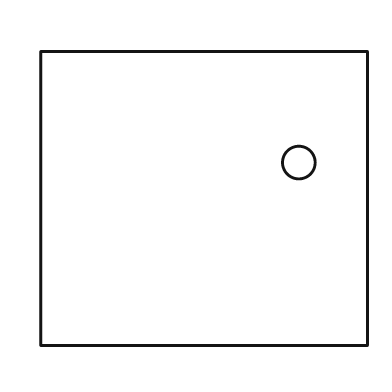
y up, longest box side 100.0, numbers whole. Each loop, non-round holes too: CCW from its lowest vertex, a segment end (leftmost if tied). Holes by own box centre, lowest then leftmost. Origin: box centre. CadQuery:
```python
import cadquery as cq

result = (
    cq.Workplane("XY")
    .moveTo(-50.0, -45.0)
    .lineTo(50.0, -45.0)
    .lineTo(50.0, 45.0)
    .lineTo(-50.0, 45.0)
    .close()
    .moveTo(29.0, 11.0)
    .circle(5.0)
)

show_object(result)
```